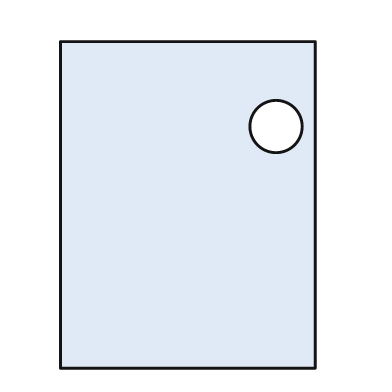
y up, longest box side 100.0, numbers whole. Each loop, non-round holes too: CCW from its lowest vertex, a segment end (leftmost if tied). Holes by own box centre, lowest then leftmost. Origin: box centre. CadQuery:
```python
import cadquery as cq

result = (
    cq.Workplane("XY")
    .moveTo(-39.0, -50.0)
    .lineTo(39.0, -50.0)
    .lineTo(39.0, 50.0)
    .lineTo(-39.0, 50.0)
    .close()
    .moveTo(27.0, 24.0)
    .circle(8.0)
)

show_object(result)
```